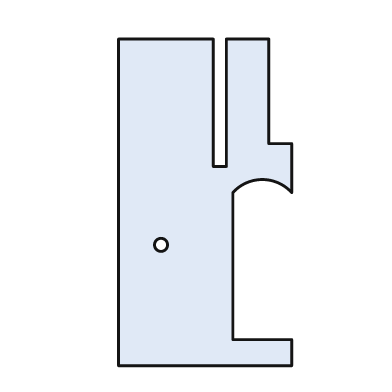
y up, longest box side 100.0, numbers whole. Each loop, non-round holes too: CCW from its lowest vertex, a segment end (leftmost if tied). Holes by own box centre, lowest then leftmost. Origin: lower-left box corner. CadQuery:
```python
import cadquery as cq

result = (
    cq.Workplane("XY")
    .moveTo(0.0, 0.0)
    .lineTo(53.0, 0.0)
    .lineTo(53.0, 8.0)
    .lineTo(35.0, 8.0)
    .lineTo(35.0, 53.0)
    .threePointArc((44.0, 57.0), (53.0, 53.0))
    .lineTo(53.0, 68.0)
    .lineTo(46.0, 68.0)
    .lineTo(46.0, 100.0)
    .lineTo(33.0, 100.0)
    .lineTo(33.0, 61.0)
    .lineTo(29.0, 61.0)
    .lineTo(29.0, 100.0)
    .lineTo(0.0, 100.0)
    .close()
    .moveTo(13.0, 37.0)
    .circle(2.0)
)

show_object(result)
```